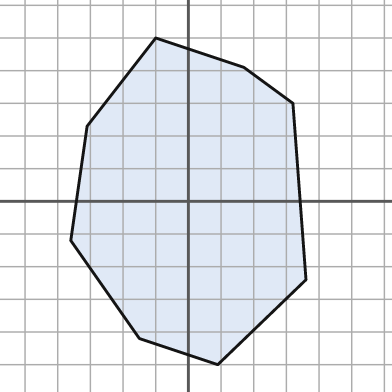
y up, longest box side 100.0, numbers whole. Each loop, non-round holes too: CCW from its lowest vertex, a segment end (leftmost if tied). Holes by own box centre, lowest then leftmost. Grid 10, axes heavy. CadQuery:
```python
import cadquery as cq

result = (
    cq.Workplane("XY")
    .moveTo(9.0, -50.0)
    .lineTo(36.0, -24.0)
    .lineTo(32.0, 30.0)
    .lineTo(17.0, 41.0)
    .lineTo(-10.0, 50.0)
    .lineTo(-31.0, 23.0)
    .lineTo(-36.0, -12.0)
    .lineTo(-15.0, -42.0)
    .close()
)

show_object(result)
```